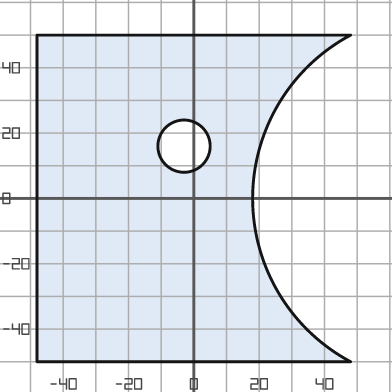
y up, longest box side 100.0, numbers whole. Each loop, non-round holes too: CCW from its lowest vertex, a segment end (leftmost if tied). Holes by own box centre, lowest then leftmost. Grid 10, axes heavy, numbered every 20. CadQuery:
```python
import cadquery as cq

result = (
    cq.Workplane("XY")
    .moveTo(-48.0, -50.0)
    .lineTo(48.0, -50.0)
    .threePointArc((18.0, 0.0), (48.0, 50.0))
    .lineTo(-48.0, 50.0)
    .close()
    .moveTo(-3.0, 16.0)
    .circle(8.0)
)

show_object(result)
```